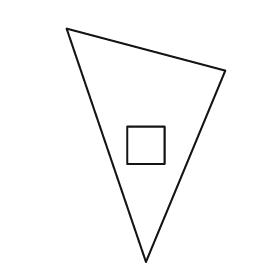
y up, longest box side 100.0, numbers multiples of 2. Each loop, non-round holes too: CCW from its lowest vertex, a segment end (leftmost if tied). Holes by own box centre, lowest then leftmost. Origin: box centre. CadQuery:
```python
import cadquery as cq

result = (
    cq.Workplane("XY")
    .moveTo(0.0, -50.0)
    .lineTo(34.0, 32.0)
    .lineTo(-34.0, 50.0)
    .close()
    .moveTo(-8.0, -8.0)
    .lineTo(8.0, -8.0)
    .lineTo(8.0, 8.0)
    .lineTo(-8.0, 8.0)
    .close()
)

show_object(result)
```